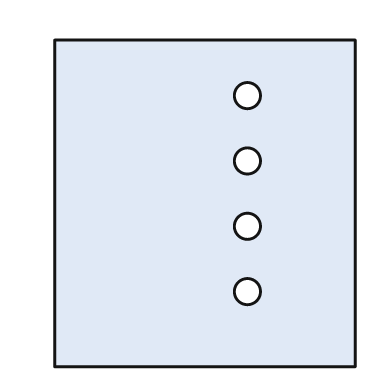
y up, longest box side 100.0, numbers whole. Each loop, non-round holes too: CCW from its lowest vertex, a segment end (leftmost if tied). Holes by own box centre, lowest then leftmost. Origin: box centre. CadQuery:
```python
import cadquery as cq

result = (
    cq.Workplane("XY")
    .moveTo(-46.0, -50.0)
    .lineTo(46.0, -50.0)
    .lineTo(46.0, 50.0)
    .lineTo(-46.0, 50.0)
    .close()
    .moveTo(13.0, -27.0)
    .circle(4.0)
    .moveTo(13.0, -7.0)
    .circle(4.0)
    .moveTo(13.0, 13.0)
    .circle(4.0)
    .moveTo(13.0, 33.0)
    .circle(4.0)
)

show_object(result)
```